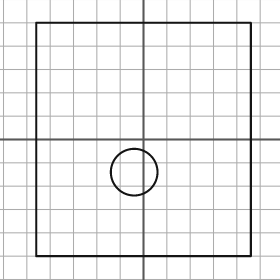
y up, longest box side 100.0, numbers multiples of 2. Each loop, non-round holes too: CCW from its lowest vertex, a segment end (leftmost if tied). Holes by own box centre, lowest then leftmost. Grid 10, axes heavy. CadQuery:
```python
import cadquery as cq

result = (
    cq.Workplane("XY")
    .moveTo(-46.0, -50.0)
    .lineTo(46.0, -50.0)
    .lineTo(46.0, 50.0)
    .lineTo(-46.0, 50.0)
    .close()
    .moveTo(-4.0, -14.0)
    .circle(10.0)
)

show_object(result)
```